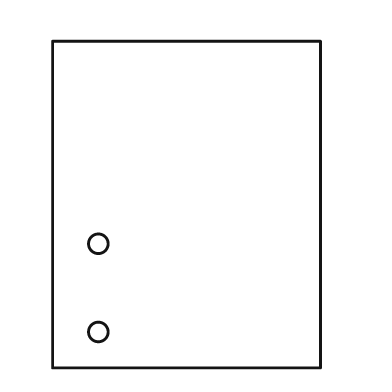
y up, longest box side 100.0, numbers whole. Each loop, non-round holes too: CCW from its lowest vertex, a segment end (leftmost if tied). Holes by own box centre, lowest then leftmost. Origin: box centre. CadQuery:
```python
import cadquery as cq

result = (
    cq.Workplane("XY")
    .moveTo(-41.0, -50.0)
    .lineTo(41.0, -50.0)
    .lineTo(41.0, 50.0)
    .lineTo(-41.0, 50.0)
    .close()
    .moveTo(-27.0, -39.0)
    .circle(3.0)
    .moveTo(-27.0, -12.0)
    .circle(3.0)
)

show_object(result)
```